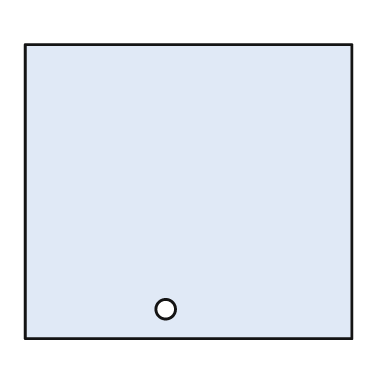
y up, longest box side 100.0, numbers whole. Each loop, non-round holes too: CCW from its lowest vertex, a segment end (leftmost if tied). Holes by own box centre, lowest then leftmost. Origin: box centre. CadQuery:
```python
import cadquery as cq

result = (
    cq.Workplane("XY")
    .moveTo(-50.0, -45.0)
    .lineTo(50.0, -45.0)
    .lineTo(50.0, 45.0)
    .lineTo(-50.0, 45.0)
    .close()
    .moveTo(-7.0, -36.0)
    .circle(3.0)
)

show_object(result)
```